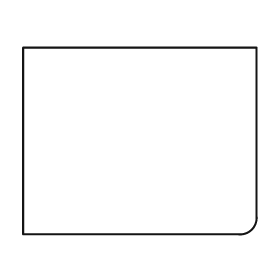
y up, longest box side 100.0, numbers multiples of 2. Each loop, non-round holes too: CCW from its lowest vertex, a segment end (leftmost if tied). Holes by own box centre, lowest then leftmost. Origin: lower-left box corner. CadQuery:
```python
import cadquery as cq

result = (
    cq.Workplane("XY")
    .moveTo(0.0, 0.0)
    .lineTo(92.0, 0.0)
    .threePointArc((98.0, 2.0), (100.0, 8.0))
    .lineTo(100.0, 80.0)
    .lineTo(0.0, 80.0)
    .close()
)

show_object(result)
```